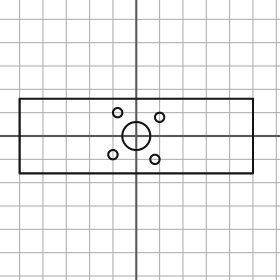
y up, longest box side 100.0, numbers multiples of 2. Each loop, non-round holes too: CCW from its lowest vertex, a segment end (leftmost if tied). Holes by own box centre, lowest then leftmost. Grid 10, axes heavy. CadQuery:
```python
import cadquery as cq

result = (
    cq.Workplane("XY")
    .moveTo(-50.0, -16.0)
    .lineTo(50.0, -16.0)
    .lineTo(50.0, 16.0)
    .lineTo(-50.0, 16.0)
    .close()
    .moveTo(8.0, -10.0)
    .circle(2.0)
    .moveTo(-10.0, -8.0)
    .circle(2.0)
    .moveTo(0.0, 0.0)
    .circle(6.0)
    .moveTo(10.0, 8.0)
    .circle(2.0)
    .moveTo(-8.0, 10.0)
    .circle(2.0)
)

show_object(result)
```